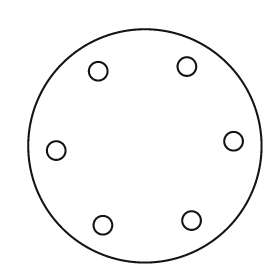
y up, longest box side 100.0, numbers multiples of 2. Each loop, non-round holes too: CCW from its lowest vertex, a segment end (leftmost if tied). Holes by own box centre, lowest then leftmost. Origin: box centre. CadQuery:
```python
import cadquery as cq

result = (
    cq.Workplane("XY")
    .moveTo(0.0, 0.0)
    .circle(50.0)
    .moveTo(-18.0, -34.0)
    .circle(4.0)
    .moveTo(20.0, -32.0)
    .circle(4.0)
    .moveTo(-38.0, -2.0)
    .circle(4.0)
    .moveTo(38.0, 2.0)
    .circle(4.0)
    .moveTo(-20.0, 32.0)
    .circle(4.0)
    .moveTo(18.0, 34.0)
    .circle(4.0)
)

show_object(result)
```